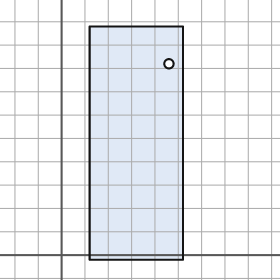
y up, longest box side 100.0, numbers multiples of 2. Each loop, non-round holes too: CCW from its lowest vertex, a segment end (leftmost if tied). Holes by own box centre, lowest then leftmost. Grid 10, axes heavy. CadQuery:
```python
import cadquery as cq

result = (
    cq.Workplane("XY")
    .moveTo(12.0, -2.0)
    .lineTo(52.0, -2.0)
    .lineTo(52.0, 98.0)
    .lineTo(12.0, 98.0)
    .close()
    .moveTo(46.0, 82.0)
    .circle(2.0)
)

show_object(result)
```